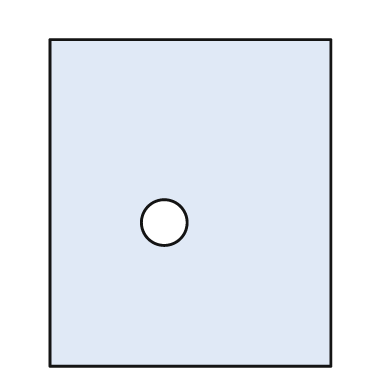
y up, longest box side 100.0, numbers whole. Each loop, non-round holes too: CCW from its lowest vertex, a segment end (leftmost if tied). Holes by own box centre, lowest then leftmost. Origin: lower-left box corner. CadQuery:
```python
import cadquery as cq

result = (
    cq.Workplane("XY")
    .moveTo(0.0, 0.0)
    .lineTo(86.0, 0.0)
    .lineTo(86.0, 100.0)
    .lineTo(0.0, 100.0)
    .close()
    .moveTo(35.0, 44.0)
    .circle(7.0)
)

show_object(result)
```